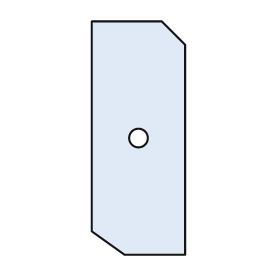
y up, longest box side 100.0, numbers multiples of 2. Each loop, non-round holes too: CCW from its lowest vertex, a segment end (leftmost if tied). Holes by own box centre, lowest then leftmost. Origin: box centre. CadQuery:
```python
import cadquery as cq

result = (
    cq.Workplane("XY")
    .moveTo(-6.0, -50.0)
    .lineTo(20.0, -50.0)
    .lineTo(20.0, 40.0)
    .lineTo(10.0, 50.0)
    .lineTo(-20.0, 50.0)
    .lineTo(-20.0, -40.0)
    .close()
    .moveTo(0.0, 0.0)
    .circle(4.0)
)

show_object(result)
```